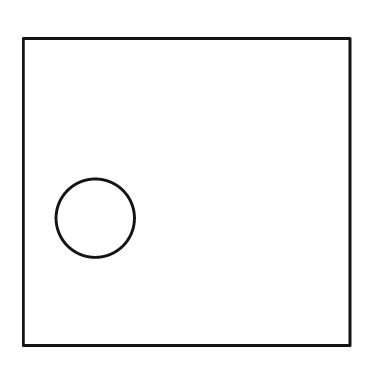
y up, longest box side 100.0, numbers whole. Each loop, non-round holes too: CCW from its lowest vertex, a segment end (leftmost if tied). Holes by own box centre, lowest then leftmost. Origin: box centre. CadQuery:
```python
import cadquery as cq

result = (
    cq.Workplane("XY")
    .moveTo(-50.0, -47.0)
    .lineTo(50.0, -47.0)
    .lineTo(50.0, 47.0)
    .lineTo(-50.0, 47.0)
    .close()
    .moveTo(-28.0, -8.0)
    .circle(12.0)
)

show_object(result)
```